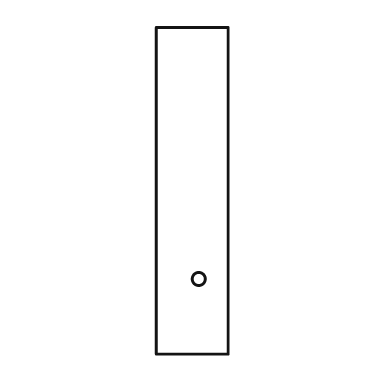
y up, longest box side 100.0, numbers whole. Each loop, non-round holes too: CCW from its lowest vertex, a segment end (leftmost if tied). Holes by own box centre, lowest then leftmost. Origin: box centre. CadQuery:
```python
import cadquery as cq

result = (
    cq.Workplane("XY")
    .moveTo(-11.0, -50.0)
    .lineTo(11.0, -50.0)
    .lineTo(11.0, 50.0)
    .lineTo(-11.0, 50.0)
    .close()
    .moveTo(2.0, -27.0)
    .circle(2.0)
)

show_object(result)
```